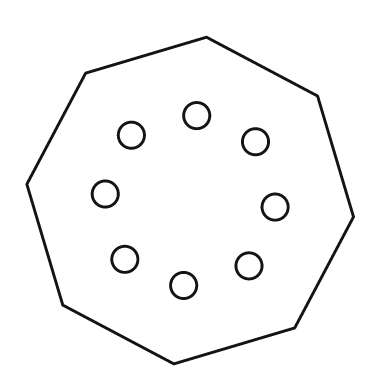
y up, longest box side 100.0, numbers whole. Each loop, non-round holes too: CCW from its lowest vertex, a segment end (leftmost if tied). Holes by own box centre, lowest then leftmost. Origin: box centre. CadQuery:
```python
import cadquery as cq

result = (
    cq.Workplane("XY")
    .moveTo(-5.0, -50.0)
    .lineTo(32.0, -39.0)
    .lineTo(50.0, -5.0)
    .lineTo(39.0, 32.0)
    .lineTo(5.0, 50.0)
    .lineTo(-32.0, 39.0)
    .lineTo(-50.0, 5.0)
    .lineTo(-39.0, -32.0)
    .close()
    .moveTo(-2.0, -26.0)
    .circle(4.0)
    .moveTo(18.0, -20.0)
    .circle(4.0)
    .moveTo(-20.0, -18.0)
    .circle(4.0)
    .moveTo(26.0, -2.0)
    .circle(4.0)
    .moveTo(-26.0, 2.0)
    .circle(4.0)
    .moveTo(20.0, 18.0)
    .circle(4.0)
    .moveTo(-18.0, 20.0)
    .circle(4.0)
    .moveTo(2.0, 26.0)
    .circle(4.0)
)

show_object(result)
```